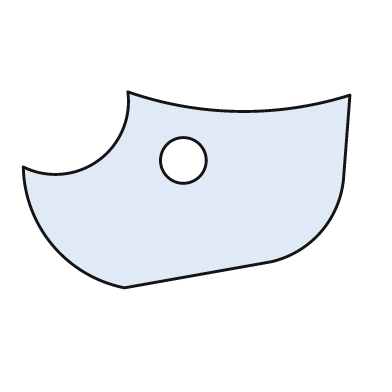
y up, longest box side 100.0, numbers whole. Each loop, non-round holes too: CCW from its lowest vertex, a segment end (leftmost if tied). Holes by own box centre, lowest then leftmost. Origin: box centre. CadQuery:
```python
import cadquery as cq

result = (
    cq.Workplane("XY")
    .moveTo(-19.0, -30.0)
    .lineTo(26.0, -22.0)
    .threePointArc((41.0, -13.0), (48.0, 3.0))
    .lineTo(50.0, 29.0)
    .threePointArc((16.0, 24.0), (-18.0, 30.0))
    .threePointArc((-27.0, 9.0), (-50.0, 7.0))
    .threePointArc((-41.0, -17.0), (-19.0, -30.0))
    .close()
    .moveTo(-1.0, 9.0)
    .circle(7.0)
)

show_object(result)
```